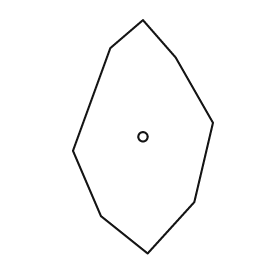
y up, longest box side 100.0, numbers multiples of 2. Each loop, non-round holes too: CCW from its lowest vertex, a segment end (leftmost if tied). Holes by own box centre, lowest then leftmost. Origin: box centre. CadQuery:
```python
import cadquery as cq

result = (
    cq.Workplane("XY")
    .moveTo(2.0, -50.0)
    .lineTo(22.0, -28.0)
    .lineTo(30.0, 6.0)
    .lineTo(14.0, 34.0)
    .lineTo(0.0, 50.0)
    .lineTo(-14.0, 38.0)
    .lineTo(-30.0, -6.0)
    .lineTo(-18.0, -34.0)
    .close()
    .moveTo(0.0, 0.0)
    .circle(2.0)
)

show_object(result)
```